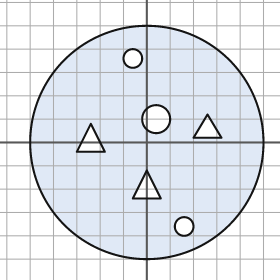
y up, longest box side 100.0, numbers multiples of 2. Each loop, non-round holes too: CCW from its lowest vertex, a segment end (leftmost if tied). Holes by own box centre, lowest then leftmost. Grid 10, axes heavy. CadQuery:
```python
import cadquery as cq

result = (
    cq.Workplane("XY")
    .moveTo(0.0, 0.0)
    .circle(50.0)
    .moveTo(16.0, -36.0)
    .circle(4.0)
    .moveTo(-6.0, -24.0)
    .lineTo(6.0, -24.0)
    .lineTo(0.0, -12.0)
    .close()
    .moveTo(-30.0, -4.0)
    .lineTo(-18.0, -4.0)
    .lineTo(-24.0, 8.0)
    .close()
    .moveTo(20.0, 2.0)
    .lineTo(32.0, 2.0)
    .lineTo(26.0, 12.0)
    .close()
    .moveTo(4.0, 10.0)
    .circle(6.0)
    .moveTo(-6.0, 36.0)
    .circle(4.0)
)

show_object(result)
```